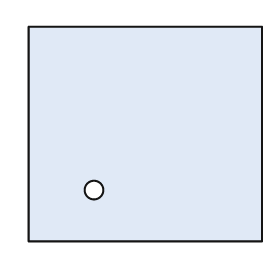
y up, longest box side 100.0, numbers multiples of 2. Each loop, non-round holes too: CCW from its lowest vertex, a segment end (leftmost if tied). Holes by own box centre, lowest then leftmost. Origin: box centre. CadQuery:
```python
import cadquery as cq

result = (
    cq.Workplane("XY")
    .moveTo(-50.0, -46.0)
    .lineTo(50.0, -46.0)
    .lineTo(50.0, 46.0)
    .lineTo(-50.0, 46.0)
    .close()
    .moveTo(-22.0, -24.0)
    .circle(4.0)
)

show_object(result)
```